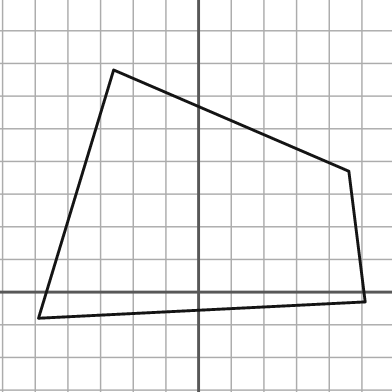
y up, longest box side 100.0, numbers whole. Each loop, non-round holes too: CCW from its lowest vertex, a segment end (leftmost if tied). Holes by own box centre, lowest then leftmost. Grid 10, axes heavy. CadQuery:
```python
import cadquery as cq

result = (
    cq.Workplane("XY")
    .moveTo(-49.0, -8.0)
    .lineTo(51.0, -3.0)
    .lineTo(46.0, 37.0)
    .lineTo(-26.0, 68.0)
    .close()
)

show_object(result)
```